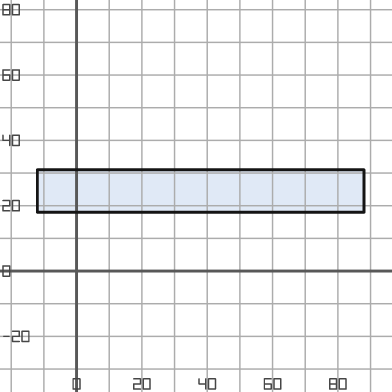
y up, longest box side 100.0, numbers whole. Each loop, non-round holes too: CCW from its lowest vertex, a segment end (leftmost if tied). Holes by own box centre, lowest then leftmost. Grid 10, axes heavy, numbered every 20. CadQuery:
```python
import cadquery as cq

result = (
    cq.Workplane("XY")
    .moveTo(-12.0, 18.0)
    .lineTo(88.0, 18.0)
    .lineTo(88.0, 31.0)
    .lineTo(-12.0, 31.0)
    .close()
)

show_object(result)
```